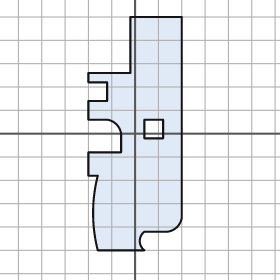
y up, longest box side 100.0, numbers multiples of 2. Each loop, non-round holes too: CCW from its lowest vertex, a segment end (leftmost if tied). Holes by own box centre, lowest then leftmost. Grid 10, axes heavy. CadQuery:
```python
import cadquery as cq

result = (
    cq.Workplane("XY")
    .moveTo(-16.0, -50.0)
    .lineTo(4.0, -50.0)
    .threePointArc((2.0, -46.0), (4.0, -42.0))
    .lineTo(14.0, -42.0)
    .threePointArc((18.0, -40.0), (20.0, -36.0))
    .lineTo(20.0, 50.0)
    .lineTo(-2.0, 50.0)
    .lineTo(-2.0, 26.0)
    .lineTo(-20.0, 26.0)
    .lineTo(-20.0, 22.0)
    .lineTo(-12.0, 22.0)
    .lineTo(-12.0, 14.0)
    .lineTo(-20.0, 14.0)
    .lineTo(-20.0, 6.0)
    .lineTo(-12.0, 6.0)
    .threePointArc((-8.0, 4.0), (-6.0, 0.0))
    .lineTo(-6.0, -8.0)
    .lineTo(-20.0, -8.0)
    .lineTo(-20.0, -18.0)
    .lineTo(-16.0, -18.0)
    .threePointArc((-18.0, -34.0), (-16.0, -50.0))
    .close()
    .moveTo(4.0, -2.0)
    .lineTo(12.0, -2.0)
    .lineTo(12.0, 6.0)
    .lineTo(4.0, 6.0)
    .close()
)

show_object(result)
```